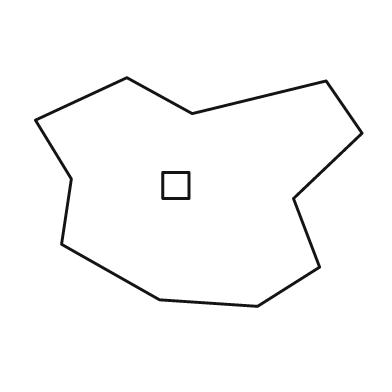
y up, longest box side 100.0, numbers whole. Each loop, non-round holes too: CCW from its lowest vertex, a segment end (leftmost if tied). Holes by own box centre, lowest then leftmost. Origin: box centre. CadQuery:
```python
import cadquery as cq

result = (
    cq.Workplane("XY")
    .moveTo(18.0, -35.0)
    .lineTo(37.0, -23.0)
    .lineTo(29.0, -2.0)
    .lineTo(50.0, 18.0)
    .lineTo(39.0, 34.0)
    .lineTo(-2.0, 24.0)
    .lineTo(-22.0, 35.0)
    .lineTo(-50.0, 22.0)
    .lineTo(-39.0, 4.0)
    .lineTo(-42.0, -16.0)
    .lineTo(-12.0, -33.0)
    .close()
    .moveTo(-11.0, -2.0)
    .lineTo(-3.0, -2.0)
    .lineTo(-3.0, 6.0)
    .lineTo(-11.0, 6.0)
    .close()
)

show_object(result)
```